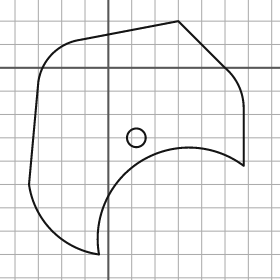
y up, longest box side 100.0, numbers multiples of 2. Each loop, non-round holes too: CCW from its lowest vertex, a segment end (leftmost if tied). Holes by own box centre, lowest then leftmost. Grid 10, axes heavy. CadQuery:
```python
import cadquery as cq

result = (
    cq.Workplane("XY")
    .moveTo(-4.0, -80.0)
    .threePointArc((14.0, -40.0), (58.0, -42.0))
    .lineTo(58.0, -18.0)
    .threePointArc((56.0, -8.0), (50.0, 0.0))
    .lineTo(30.0, 20.0)
    .lineTo(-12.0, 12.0)
    .threePointArc((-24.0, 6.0), (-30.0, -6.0))
    .lineTo(-34.0, -50.0)
    .threePointArc((-24.0, -70.0), (-4.0, -80.0))
    .close()
    .moveTo(12.0, -30.0)
    .circle(4.0)
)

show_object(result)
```